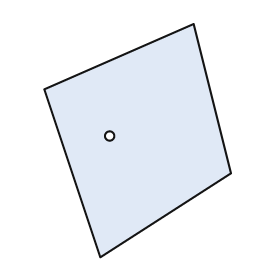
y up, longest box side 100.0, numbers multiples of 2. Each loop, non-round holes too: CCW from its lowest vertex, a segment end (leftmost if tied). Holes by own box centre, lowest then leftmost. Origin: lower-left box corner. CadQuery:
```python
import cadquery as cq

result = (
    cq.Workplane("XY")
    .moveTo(24.0, 0.0)
    .lineTo(80.0, 36.0)
    .lineTo(64.0, 100.0)
    .lineTo(0.0, 72.0)
    .close()
    .moveTo(28.0, 52.0)
    .circle(2.0)
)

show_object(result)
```